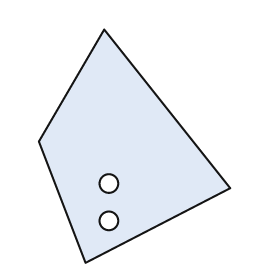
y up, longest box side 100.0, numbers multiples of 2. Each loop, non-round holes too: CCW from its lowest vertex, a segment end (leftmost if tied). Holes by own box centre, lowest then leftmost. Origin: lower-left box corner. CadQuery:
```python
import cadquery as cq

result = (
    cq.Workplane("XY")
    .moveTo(20.0, 0.0)
    .lineTo(82.0, 32.0)
    .lineTo(28.0, 100.0)
    .lineTo(0.0, 52.0)
    .close()
    .moveTo(30.0, 18.0)
    .circle(4.0)
    .moveTo(30.0, 34.0)
    .circle(4.0)
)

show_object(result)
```